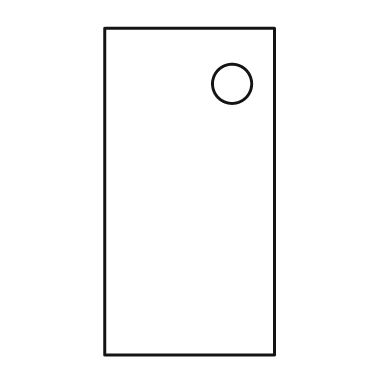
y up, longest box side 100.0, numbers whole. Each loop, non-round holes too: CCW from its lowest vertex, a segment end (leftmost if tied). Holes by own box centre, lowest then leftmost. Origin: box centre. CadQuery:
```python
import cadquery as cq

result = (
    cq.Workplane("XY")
    .moveTo(-26.0, -50.0)
    .lineTo(26.0, -50.0)
    .lineTo(26.0, 50.0)
    .lineTo(-26.0, 50.0)
    .close()
    .moveTo(13.0, 33.0)
    .circle(6.0)
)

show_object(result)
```